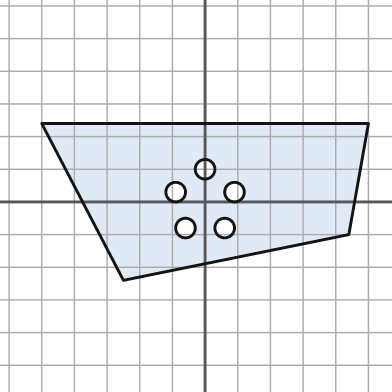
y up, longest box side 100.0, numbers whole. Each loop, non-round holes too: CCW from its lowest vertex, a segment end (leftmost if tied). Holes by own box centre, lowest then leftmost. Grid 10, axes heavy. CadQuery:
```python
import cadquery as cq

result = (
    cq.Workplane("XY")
    .moveTo(-25.0, -24.0)
    .lineTo(44.0, -10.0)
    .lineTo(50.0, 24.0)
    .lineTo(-50.0, 24.0)
    .close()
    .moveTo(-6.0, -8.0)
    .circle(3.0)
    .moveTo(6.0, -8.0)
    .circle(3.0)
    .moveTo(-9.0, 3.0)
    .circle(3.0)
    .moveTo(9.0, 3.0)
    .circle(3.0)
    .moveTo(0.0, 10.0)
    .circle(3.0)
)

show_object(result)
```